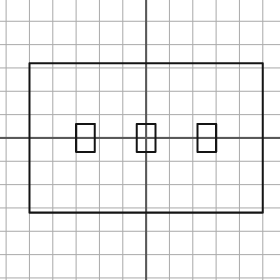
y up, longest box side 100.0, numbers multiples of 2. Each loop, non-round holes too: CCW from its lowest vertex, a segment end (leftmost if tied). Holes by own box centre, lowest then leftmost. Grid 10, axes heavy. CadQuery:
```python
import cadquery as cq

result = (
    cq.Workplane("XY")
    .moveTo(-50.0, -32.0)
    .lineTo(50.0, -32.0)
    .lineTo(50.0, 32.0)
    .lineTo(-50.0, 32.0)
    .close()
    .moveTo(-30.0, -6.0)
    .lineTo(-22.0, -6.0)
    .lineTo(-22.0, 6.0)
    .lineTo(-30.0, 6.0)
    .close()
    .moveTo(-4.0, -6.0)
    .lineTo(4.0, -6.0)
    .lineTo(4.0, 6.0)
    .lineTo(-4.0, 6.0)
    .close()
    .moveTo(22.0, -6.0)
    .lineTo(30.0, -6.0)
    .lineTo(30.0, 6.0)
    .lineTo(22.0, 6.0)
    .close()
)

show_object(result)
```